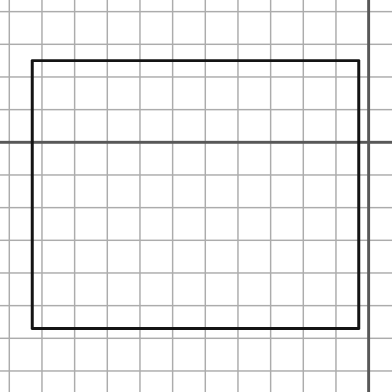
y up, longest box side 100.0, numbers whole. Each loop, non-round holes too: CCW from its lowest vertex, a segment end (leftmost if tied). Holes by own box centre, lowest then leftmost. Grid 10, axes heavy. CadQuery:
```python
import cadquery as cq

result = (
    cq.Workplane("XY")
    .moveTo(-103.0, -57.0)
    .lineTo(-3.0, -57.0)
    .lineTo(-3.0, 25.0)
    .lineTo(-103.0, 25.0)
    .close()
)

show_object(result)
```